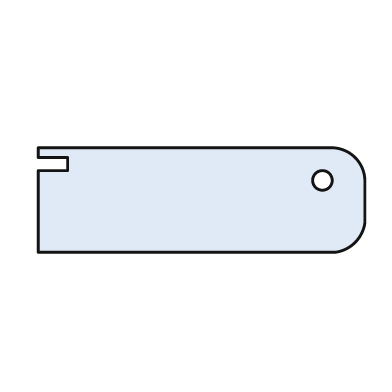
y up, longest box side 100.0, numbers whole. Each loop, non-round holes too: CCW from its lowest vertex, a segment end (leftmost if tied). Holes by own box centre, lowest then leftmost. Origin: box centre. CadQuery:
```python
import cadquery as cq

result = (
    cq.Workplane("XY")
    .moveTo(-50.0, -16.0)
    .lineTo(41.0, -16.0)
    .threePointArc((47.0, -13.0), (50.0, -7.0))
    .lineTo(50.0, 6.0)
    .threePointArc((47.0, 13.0), (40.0, 16.0))
    .lineTo(-50.0, 16.0)
    .lineTo(-50.0, 13.0)
    .lineTo(-41.0, 13.0)
    .lineTo(-41.0, 9.0)
    .lineTo(-50.0, 9.0)
    .close()
    .moveTo(37.0, 6.0)
    .circle(3.0)
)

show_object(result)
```